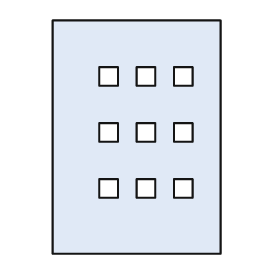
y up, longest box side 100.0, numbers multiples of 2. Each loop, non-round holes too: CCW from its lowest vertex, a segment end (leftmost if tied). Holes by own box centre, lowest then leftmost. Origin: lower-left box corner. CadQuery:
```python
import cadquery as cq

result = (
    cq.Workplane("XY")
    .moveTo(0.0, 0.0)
    .lineTo(72.0, 0.0)
    .lineTo(72.0, 100.0)
    .lineTo(0.0, 100.0)
    .close()
    .moveTo(20.0, 24.0)
    .lineTo(28.0, 24.0)
    .lineTo(28.0, 32.0)
    .lineTo(20.0, 32.0)
    .close()
    .moveTo(36.0, 24.0)
    .lineTo(44.0, 24.0)
    .lineTo(44.0, 32.0)
    .lineTo(36.0, 32.0)
    .close()
    .moveTo(52.0, 24.0)
    .lineTo(60.0, 24.0)
    .lineTo(60.0, 32.0)
    .lineTo(52.0, 32.0)
    .close()
    .moveTo(20.0, 48.0)
    .lineTo(28.0, 48.0)
    .lineTo(28.0, 56.0)
    .lineTo(20.0, 56.0)
    .close()
    .moveTo(36.0, 48.0)
    .lineTo(44.0, 48.0)
    .lineTo(44.0, 56.0)
    .lineTo(36.0, 56.0)
    .close()
    .moveTo(52.0, 48.0)
    .lineTo(60.0, 48.0)
    .lineTo(60.0, 56.0)
    .lineTo(52.0, 56.0)
    .close()
    .moveTo(20.0, 72.0)
    .lineTo(28.0, 72.0)
    .lineTo(28.0, 80.0)
    .lineTo(20.0, 80.0)
    .close()
    .moveTo(36.0, 72.0)
    .lineTo(44.0, 72.0)
    .lineTo(44.0, 80.0)
    .lineTo(36.0, 80.0)
    .close()
    .moveTo(52.0, 72.0)
    .lineTo(60.0, 72.0)
    .lineTo(60.0, 80.0)
    .lineTo(52.0, 80.0)
    .close()
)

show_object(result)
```